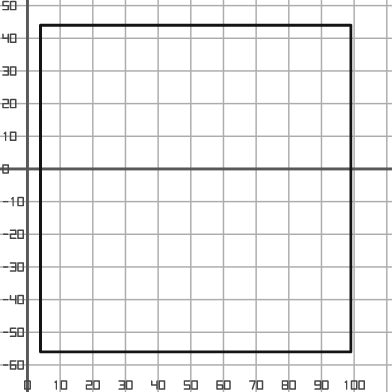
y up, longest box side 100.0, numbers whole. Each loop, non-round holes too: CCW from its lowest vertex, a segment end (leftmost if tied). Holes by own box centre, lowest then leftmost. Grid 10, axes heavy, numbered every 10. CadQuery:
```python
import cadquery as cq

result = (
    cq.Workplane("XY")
    .moveTo(4.0, -56.0)
    .lineTo(99.0, -56.0)
    .lineTo(99.0, 44.0)
    .lineTo(4.0, 44.0)
    .close()
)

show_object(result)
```